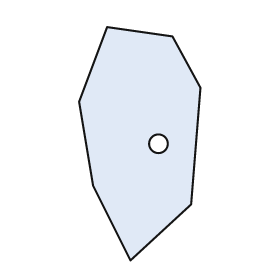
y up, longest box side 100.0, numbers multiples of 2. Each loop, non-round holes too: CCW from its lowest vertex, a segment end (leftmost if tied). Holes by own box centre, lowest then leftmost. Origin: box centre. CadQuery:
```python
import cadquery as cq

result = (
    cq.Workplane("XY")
    .moveTo(-4.0, -50.0)
    .lineTo(22.0, -26.0)
    .lineTo(26.0, 24.0)
    .lineTo(14.0, 46.0)
    .lineTo(-14.0, 50.0)
    .lineTo(-26.0, 18.0)
    .lineTo(-20.0, -18.0)
    .close()
    .moveTo(8.0, 0.0)
    .circle(4.0)
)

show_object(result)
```